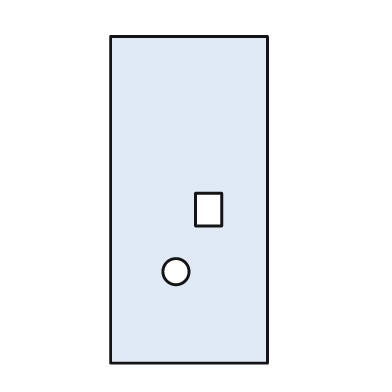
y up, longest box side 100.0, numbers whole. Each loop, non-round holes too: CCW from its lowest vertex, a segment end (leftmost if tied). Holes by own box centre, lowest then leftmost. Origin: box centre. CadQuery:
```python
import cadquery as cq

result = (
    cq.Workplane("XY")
    .moveTo(-24.0, -50.0)
    .lineTo(24.0, -50.0)
    .lineTo(24.0, 50.0)
    .lineTo(-24.0, 50.0)
    .close()
    .moveTo(-4.0, -22.0)
    .circle(4.0)
    .moveTo(2.0, -8.0)
    .lineTo(10.0, -8.0)
    .lineTo(10.0, 2.0)
    .lineTo(2.0, 2.0)
    .close()
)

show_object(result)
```